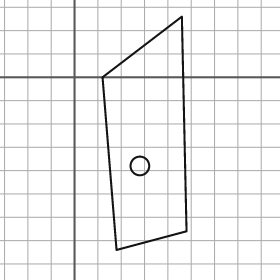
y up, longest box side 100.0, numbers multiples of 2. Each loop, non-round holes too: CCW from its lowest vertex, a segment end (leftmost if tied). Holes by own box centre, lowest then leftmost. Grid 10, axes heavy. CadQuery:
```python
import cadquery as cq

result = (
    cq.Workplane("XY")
    .moveTo(18.0, -74.0)
    .lineTo(48.0, -66.0)
    .lineTo(46.0, 26.0)
    .lineTo(12.0, 0.0)
    .close()
    .moveTo(28.0, -38.0)
    .circle(4.0)
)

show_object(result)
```